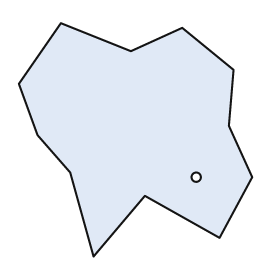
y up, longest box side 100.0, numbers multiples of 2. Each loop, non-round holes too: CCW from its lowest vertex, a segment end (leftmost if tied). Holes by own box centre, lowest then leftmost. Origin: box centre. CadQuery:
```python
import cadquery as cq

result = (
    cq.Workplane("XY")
    .moveTo(-18.0, -50.0)
    .lineTo(4.0, -24.0)
    .lineTo(36.0, -42.0)
    .lineTo(50.0, -16.0)
    .lineTo(40.0, 6.0)
    .lineTo(42.0, 30.0)
    .lineTo(20.0, 48.0)
    .lineTo(-2.0, 38.0)
    .lineTo(-32.0, 50.0)
    .lineTo(-50.0, 24.0)
    .lineTo(-42.0, 2.0)
    .lineTo(-28.0, -14.0)
    .close()
    .moveTo(26.0, -16.0)
    .circle(2.0)
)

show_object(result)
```